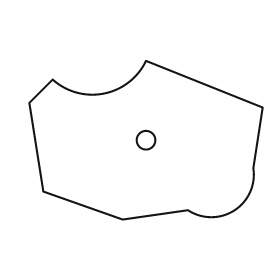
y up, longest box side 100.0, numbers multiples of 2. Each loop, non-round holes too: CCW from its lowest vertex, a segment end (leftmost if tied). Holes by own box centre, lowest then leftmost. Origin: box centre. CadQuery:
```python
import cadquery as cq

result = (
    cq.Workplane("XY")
    .moveTo(-10.0, -34.0)
    .lineTo(18.0, -30.0)
    .threePointArc((38.0, -30.0), (46.0, -12.0))
    .lineTo(50.0, 14.0)
    .lineTo(0.0, 34.0)
    .threePointArc((-18.0, 20.0), (-40.0, 26.0))
    .lineTo(-50.0, 16.0)
    .lineTo(-44.0, -22.0)
    .close()
    .moveTo(0.0, 0.0)
    .circle(4.0)
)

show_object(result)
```